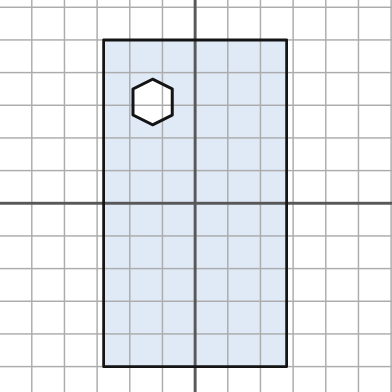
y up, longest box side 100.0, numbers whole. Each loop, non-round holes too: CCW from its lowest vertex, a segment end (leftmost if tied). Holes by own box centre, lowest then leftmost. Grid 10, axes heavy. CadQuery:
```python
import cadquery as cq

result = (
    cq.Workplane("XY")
    .moveTo(-28.0, -50.0)
    .lineTo(28.0, -50.0)
    .lineTo(28.0, 50.0)
    .lineTo(-28.0, 50.0)
    .close()
    .moveTo(-13.0, 24.0)
    .lineTo(-7.0, 27.0)
    .lineTo(-7.0, 35.0)
    .lineTo(-13.0, 38.0)
    .lineTo(-19.0, 35.0)
    .lineTo(-19.0, 27.0)
    .close()
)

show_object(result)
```